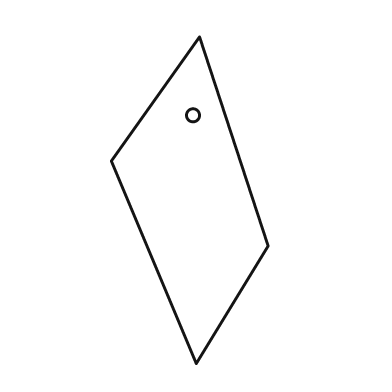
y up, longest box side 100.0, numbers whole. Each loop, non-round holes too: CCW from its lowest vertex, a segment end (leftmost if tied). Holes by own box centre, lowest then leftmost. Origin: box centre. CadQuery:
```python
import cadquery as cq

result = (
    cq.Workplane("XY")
    .moveTo(2.0, -50.0)
    .lineTo(24.0, -14.0)
    .lineTo(3.0, 50.0)
    .lineTo(-24.0, 12.0)
    .close()
    .moveTo(1.0, 26.0)
    .circle(2.0)
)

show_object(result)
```